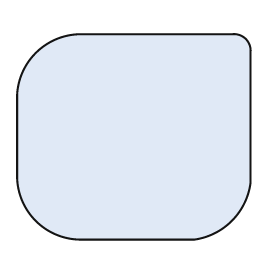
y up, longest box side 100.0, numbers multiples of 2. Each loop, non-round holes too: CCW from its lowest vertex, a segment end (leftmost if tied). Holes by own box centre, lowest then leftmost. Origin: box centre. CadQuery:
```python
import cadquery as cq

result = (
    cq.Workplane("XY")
    .moveTo(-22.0, -44.0)
    .lineTo(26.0, -44.0)
    .threePointArc((42.0, -36.0), (50.0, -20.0))
    .lineTo(50.0, 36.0)
    .threePointArc((48.0, 42.0), (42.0, 44.0))
    .lineTo(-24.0, 44.0)
    .threePointArc((-42.0, 36.0), (-50.0, 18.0))
    .lineTo(-50.0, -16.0)
    .threePointArc((-42.0, -36.0), (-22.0, -44.0))
    .close()
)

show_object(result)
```